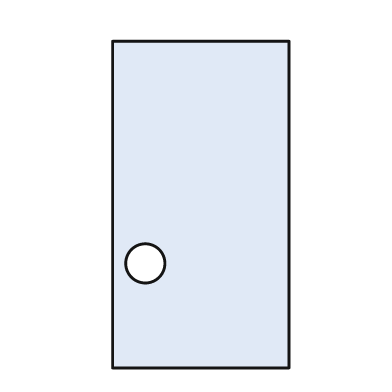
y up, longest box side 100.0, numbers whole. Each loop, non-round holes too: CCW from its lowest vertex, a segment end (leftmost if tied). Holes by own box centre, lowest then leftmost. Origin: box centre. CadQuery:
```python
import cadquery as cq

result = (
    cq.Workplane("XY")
    .moveTo(-27.0, -50.0)
    .lineTo(27.0, -50.0)
    .lineTo(27.0, 50.0)
    .lineTo(-27.0, 50.0)
    .close()
    .moveTo(-17.0, -18.0)
    .circle(6.0)
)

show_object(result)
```